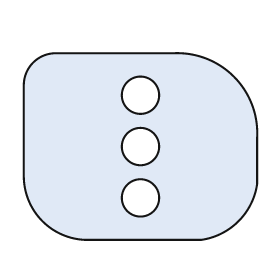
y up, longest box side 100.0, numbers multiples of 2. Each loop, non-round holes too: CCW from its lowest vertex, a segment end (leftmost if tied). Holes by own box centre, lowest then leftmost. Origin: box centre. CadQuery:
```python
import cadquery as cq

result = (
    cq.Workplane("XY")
    .moveTo(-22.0, -40.0)
    .lineTo(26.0, -40.0)
    .threePointArc((42.0, -32.0), (50.0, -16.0))
    .lineTo(50.0, 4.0)
    .threePointArc((40.0, 30.0), (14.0, 40.0))
    .lineTo(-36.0, 40.0)
    .threePointArc((-46.0, 36.0), (-50.0, 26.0))
    .lineTo(-50.0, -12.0)
    .threePointArc((-42.0, -32.0), (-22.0, -40.0))
    .close()
    .moveTo(0.0, -22.0)
    .circle(8.0)
    .moveTo(0.0, 0.0)
    .circle(8.0)
    .moveTo(0.0, 22.0)
    .circle(8.0)
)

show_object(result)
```